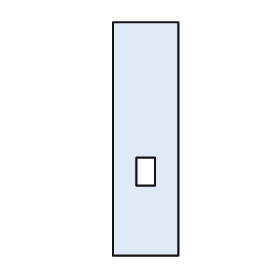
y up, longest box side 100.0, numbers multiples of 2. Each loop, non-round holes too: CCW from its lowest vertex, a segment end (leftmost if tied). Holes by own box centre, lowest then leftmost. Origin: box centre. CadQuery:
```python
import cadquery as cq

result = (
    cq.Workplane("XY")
    .moveTo(-14.0, -50.0)
    .lineTo(14.0, -50.0)
    .lineTo(14.0, 50.0)
    .lineTo(-14.0, 50.0)
    .close()
    .moveTo(-4.0, -20.0)
    .lineTo(4.0, -20.0)
    .lineTo(4.0, -8.0)
    .lineTo(-4.0, -8.0)
    .close()
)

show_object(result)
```